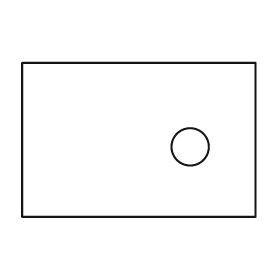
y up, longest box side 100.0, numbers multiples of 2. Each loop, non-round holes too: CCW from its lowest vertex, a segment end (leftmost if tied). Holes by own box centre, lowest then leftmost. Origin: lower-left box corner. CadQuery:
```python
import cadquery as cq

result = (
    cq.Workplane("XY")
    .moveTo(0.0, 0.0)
    .lineTo(100.0, 0.0)
    .lineTo(100.0, 66.0)
    .lineTo(0.0, 66.0)
    .close()
    .moveTo(72.0, 30.0)
    .circle(8.0)
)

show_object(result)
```